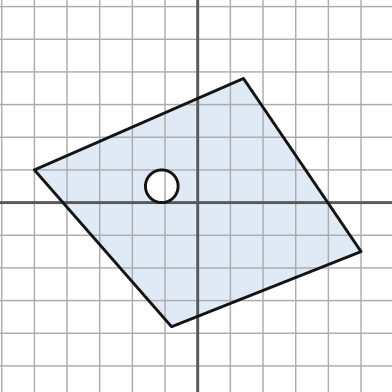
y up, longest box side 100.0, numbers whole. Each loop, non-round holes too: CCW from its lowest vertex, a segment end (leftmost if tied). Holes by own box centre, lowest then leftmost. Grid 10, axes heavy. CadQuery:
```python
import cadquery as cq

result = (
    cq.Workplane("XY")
    .moveTo(-8.0, -38.0)
    .lineTo(50.0, -15.0)
    .lineTo(14.0, 38.0)
    .lineTo(-50.0, 10.0)
    .close()
    .moveTo(-11.0, 5.0)
    .circle(5.0)
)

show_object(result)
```